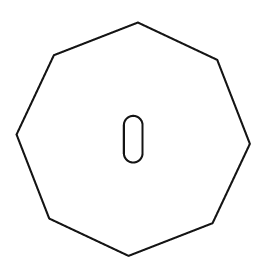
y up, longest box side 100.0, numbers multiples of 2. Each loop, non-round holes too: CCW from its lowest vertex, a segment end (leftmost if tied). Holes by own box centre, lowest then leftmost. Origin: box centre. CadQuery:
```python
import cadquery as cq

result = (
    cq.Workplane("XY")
    .moveTo(-2.0, -50.0)
    .lineTo(34.0, -36.0)
    .lineTo(50.0, -2.0)
    .lineTo(36.0, 34.0)
    .lineTo(2.0, 50.0)
    .lineTo(-34.0, 36.0)
    .lineTo(-50.0, 2.0)
    .lineTo(-36.0, -34.0)
    .close()
    .moveTo(-4.0, -6.0)
    .threePointArc((0.0, -10.0), (4.0, -6.0))
    .lineTo(4.0, 6.0)
    .threePointArc((0.0, 10.0), (-4.0, 6.0))
    .close()
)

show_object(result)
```